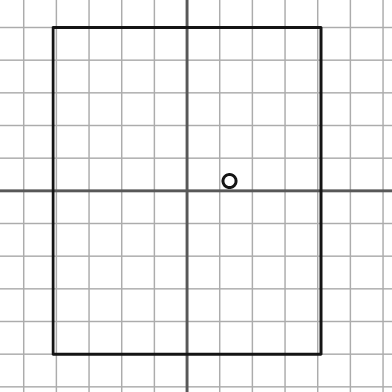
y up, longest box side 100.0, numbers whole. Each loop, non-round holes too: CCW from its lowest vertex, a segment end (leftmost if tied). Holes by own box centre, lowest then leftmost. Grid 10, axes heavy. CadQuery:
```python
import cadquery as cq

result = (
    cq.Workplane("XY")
    .moveTo(-41.0, -50.0)
    .lineTo(41.0, -50.0)
    .lineTo(41.0, 50.0)
    .lineTo(-41.0, 50.0)
    .close()
    .moveTo(13.0, 3.0)
    .circle(2.0)
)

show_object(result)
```